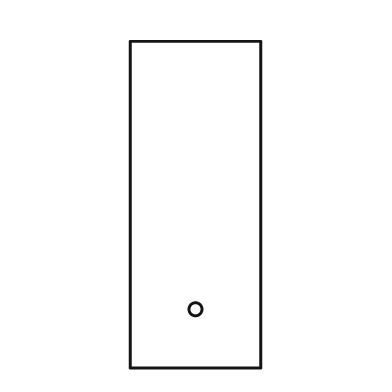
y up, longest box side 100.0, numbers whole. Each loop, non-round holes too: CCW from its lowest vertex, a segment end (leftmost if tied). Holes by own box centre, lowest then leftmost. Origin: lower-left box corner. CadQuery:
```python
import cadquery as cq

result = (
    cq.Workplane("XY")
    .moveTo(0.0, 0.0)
    .lineTo(40.0, 0.0)
    .lineTo(40.0, 100.0)
    .lineTo(0.0, 100.0)
    .close()
    .moveTo(20.0, 18.0)
    .circle(2.0)
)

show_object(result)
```